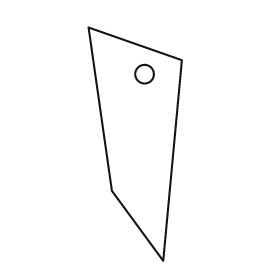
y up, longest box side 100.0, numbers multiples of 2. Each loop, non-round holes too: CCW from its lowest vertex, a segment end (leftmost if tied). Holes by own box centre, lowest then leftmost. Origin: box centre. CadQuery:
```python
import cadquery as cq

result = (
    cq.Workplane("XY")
    .moveTo(12.0, -50.0)
    .lineTo(20.0, 36.0)
    .lineTo(-20.0, 50.0)
    .lineTo(-10.0, -20.0)
    .close()
    .moveTo(4.0, 30.0)
    .circle(4.0)
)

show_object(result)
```